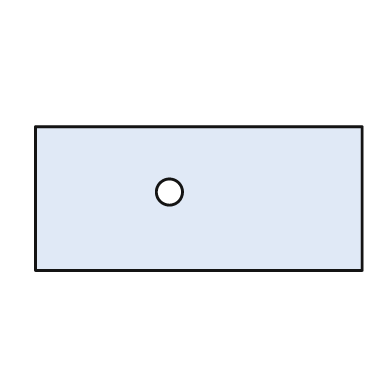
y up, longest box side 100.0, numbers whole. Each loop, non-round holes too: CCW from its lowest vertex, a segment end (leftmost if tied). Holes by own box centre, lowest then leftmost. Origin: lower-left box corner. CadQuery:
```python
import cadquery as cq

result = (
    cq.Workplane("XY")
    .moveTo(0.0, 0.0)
    .lineTo(100.0, 0.0)
    .lineTo(100.0, 44.0)
    .lineTo(0.0, 44.0)
    .close()
    .moveTo(41.0, 24.0)
    .circle(4.0)
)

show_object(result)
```